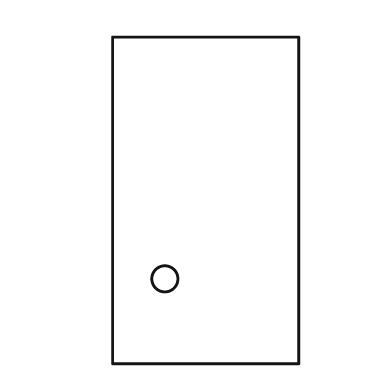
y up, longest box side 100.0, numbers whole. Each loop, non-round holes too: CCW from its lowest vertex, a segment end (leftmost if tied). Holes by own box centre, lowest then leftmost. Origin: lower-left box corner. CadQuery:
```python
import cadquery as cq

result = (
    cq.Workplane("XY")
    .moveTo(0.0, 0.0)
    .lineTo(57.0, 0.0)
    .lineTo(57.0, 100.0)
    .lineTo(0.0, 100.0)
    .close()
    .moveTo(16.0, 26.0)
    .circle(4.0)
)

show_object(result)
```